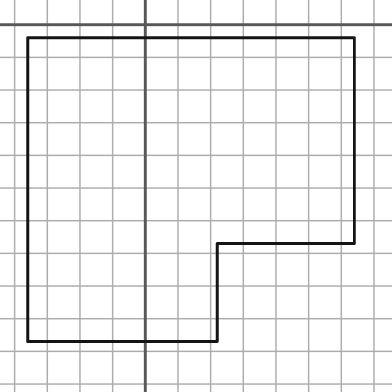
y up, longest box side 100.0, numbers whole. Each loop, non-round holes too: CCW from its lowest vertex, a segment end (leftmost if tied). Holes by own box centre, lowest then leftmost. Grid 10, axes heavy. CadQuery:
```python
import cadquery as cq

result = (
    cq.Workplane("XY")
    .moveTo(-36.0, -97.0)
    .lineTo(22.0, -97.0)
    .lineTo(22.0, -67.0)
    .lineTo(64.0, -67.0)
    .lineTo(64.0, -4.0)
    .lineTo(-36.0, -4.0)
    .close()
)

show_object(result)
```